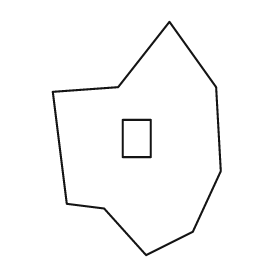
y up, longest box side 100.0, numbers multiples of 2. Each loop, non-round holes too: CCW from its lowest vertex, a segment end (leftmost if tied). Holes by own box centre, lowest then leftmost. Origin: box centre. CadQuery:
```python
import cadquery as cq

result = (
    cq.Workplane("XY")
    .moveTo(4.0, -50.0)
    .lineTo(24.0, -40.0)
    .lineTo(36.0, -14.0)
    .lineTo(34.0, 22.0)
    .lineTo(14.0, 50.0)
    .lineTo(-8.0, 22.0)
    .lineTo(-36.0, 20.0)
    .lineTo(-30.0, -28.0)
    .lineTo(-14.0, -30.0)
    .close()
    .moveTo(-6.0, -8.0)
    .lineTo(6.0, -8.0)
    .lineTo(6.0, 8.0)
    .lineTo(-6.0, 8.0)
    .close()
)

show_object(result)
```